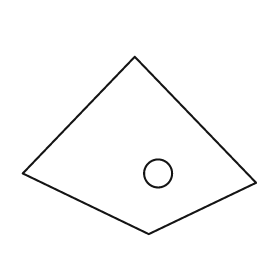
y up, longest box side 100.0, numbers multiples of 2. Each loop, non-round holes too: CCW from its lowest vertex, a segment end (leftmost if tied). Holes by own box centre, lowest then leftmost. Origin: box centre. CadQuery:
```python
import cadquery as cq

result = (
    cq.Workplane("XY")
    .moveTo(4.0, -38.0)
    .lineTo(50.0, -16.0)
    .lineTo(-2.0, 38.0)
    .lineTo(-50.0, -12.0)
    .close()
    .moveTo(8.0, -12.0)
    .circle(6.0)
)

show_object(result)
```